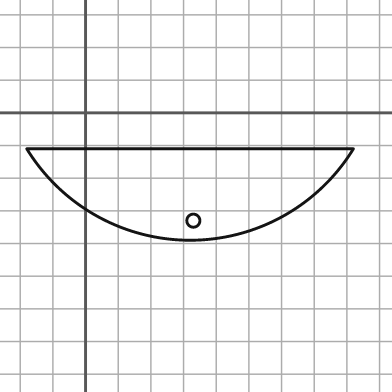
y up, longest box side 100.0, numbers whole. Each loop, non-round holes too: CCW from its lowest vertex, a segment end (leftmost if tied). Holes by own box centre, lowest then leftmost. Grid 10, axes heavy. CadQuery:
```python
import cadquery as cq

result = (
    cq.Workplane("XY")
    .moveTo(-18.0, -11.0)
    .threePointArc((32.0, -39.0), (82.0, -11.0))
    .close()
    .moveTo(33.0, -33.0)
    .circle(2.0)
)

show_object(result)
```